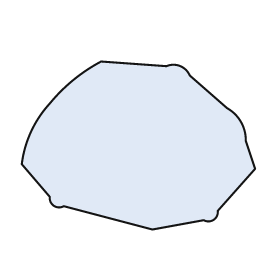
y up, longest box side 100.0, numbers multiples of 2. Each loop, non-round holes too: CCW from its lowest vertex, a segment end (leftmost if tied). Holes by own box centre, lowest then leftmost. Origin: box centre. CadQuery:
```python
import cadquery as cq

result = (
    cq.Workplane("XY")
    .moveTo(6.0, -36.0)
    .lineTo(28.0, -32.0)
    .threePointArc((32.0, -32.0), (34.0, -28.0))
    .lineTo(50.0, -10.0)
    .lineTo(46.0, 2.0)
    .threePointArc((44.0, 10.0), (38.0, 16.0))
    .lineTo(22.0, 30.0)
    .threePointArc((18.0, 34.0), (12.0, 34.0))
    .lineTo(-16.0, 36.0)
    .threePointArc((-28.0, 28.0), (-38.0, 18.0))
    .threePointArc((-46.0, 6.0), (-50.0, -8.0))
    .lineTo(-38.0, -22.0)
    .threePointArc((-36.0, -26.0), (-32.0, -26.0))
    .close()
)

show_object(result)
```